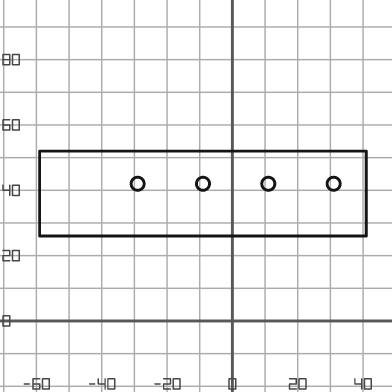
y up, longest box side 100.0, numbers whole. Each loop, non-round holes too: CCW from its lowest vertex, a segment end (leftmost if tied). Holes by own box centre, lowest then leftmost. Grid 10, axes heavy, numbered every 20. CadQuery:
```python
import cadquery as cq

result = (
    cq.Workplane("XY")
    .moveTo(-59.0, 26.0)
    .lineTo(41.0, 26.0)
    .lineTo(41.0, 52.0)
    .lineTo(-59.0, 52.0)
    .close()
    .moveTo(-29.0, 42.0)
    .circle(2.0)
    .moveTo(-9.0, 42.0)
    .circle(2.0)
    .moveTo(11.0, 42.0)
    .circle(2.0)
    .moveTo(31.0, 42.0)
    .circle(2.0)
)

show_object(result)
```